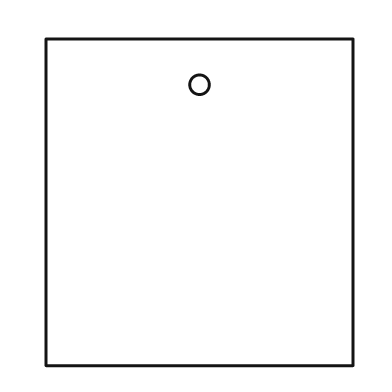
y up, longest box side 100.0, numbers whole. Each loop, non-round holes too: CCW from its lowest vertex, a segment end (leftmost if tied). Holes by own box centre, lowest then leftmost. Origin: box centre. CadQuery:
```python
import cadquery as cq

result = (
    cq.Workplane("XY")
    .moveTo(-47.0, -50.0)
    .lineTo(47.0, -50.0)
    .lineTo(47.0, 50.0)
    .lineTo(-47.0, 50.0)
    .close()
    .moveTo(0.0, 36.0)
    .circle(3.0)
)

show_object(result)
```